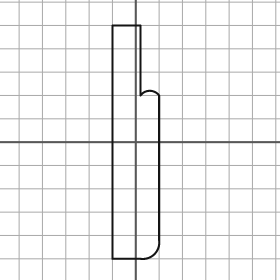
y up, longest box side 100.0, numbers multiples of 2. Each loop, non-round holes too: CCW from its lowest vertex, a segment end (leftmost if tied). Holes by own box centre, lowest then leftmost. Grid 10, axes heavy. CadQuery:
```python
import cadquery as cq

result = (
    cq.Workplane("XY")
    .moveTo(-10.0, -50.0)
    .lineTo(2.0, -50.0)
    .threePointArc((8.0, -48.0), (10.0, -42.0))
    .lineTo(10.0, 20.0)
    .threePointArc((6.0, 22.0), (2.0, 20.0))
    .lineTo(2.0, 50.0)
    .lineTo(-10.0, 50.0)
    .close()
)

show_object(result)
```